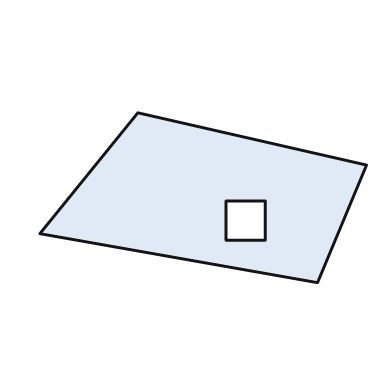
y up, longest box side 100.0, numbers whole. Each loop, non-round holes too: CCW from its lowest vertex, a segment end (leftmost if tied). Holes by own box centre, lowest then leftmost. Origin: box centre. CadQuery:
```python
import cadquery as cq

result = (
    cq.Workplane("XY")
    .moveTo(35.0, -26.0)
    .lineTo(50.0, 10.0)
    .lineTo(-20.0, 26.0)
    .lineTo(-50.0, -11.0)
    .close()
    .moveTo(7.0, -13.0)
    .lineTo(19.0, -13.0)
    .lineTo(19.0, -1.0)
    .lineTo(7.0, -1.0)
    .close()
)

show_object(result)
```